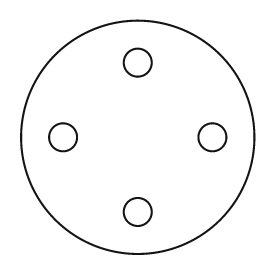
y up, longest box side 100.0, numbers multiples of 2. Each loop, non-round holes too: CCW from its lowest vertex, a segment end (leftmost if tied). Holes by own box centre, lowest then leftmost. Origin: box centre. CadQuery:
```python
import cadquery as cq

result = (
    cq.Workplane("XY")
    .moveTo(0.0, 0.0)
    .circle(50.0)
    .moveTo(0.0, -32.0)
    .circle(6.0)
    .moveTo(-32.0, 0.0)
    .circle(6.0)
    .moveTo(32.0, 0.0)
    .circle(6.0)
    .moveTo(0.0, 32.0)
    .circle(6.0)
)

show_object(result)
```